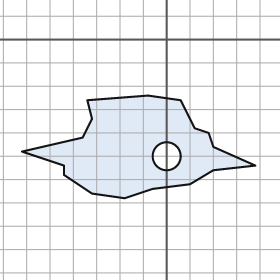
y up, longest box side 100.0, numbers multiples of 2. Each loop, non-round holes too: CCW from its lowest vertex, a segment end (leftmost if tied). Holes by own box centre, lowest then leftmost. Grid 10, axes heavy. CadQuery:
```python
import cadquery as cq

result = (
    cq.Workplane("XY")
    .moveTo(-18.0, -68.0)
    .lineTo(-6.0, -64.0)
    .lineTo(10.0, -62.0)
    .lineTo(20.0, -56.0)
    .lineTo(38.0, -54.0)
    .lineTo(20.0, -46.0)
    .lineTo(18.0, -40.0)
    .lineTo(12.0, -38.0)
    .lineTo(6.0, -26.0)
    .lineTo(-8.0, -24.0)
    .lineTo(-34.0, -26.0)
    .lineTo(-32.0, -34.0)
    .lineTo(-36.0, -42.0)
    .lineTo(-62.0, -48.0)
    .lineTo(-44.0, -54.0)
    .lineTo(-44.0, -58.0)
    .lineTo(-32.0, -66.0)
    .close()
    .moveTo(0.0, -50.0)
    .circle(6.0)
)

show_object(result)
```